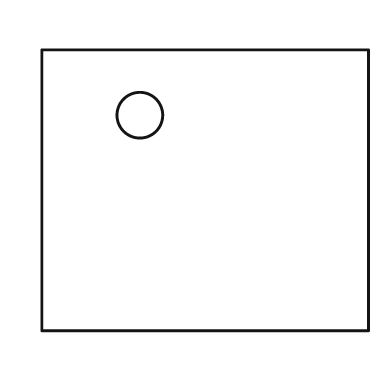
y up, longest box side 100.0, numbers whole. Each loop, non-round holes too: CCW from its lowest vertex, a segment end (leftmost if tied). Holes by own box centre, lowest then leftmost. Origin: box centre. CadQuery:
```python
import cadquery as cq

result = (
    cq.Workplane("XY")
    .moveTo(-50.0, -43.0)
    .lineTo(50.0, -43.0)
    .lineTo(50.0, 43.0)
    .lineTo(-50.0, 43.0)
    .close()
    .moveTo(-20.0, 23.0)
    .circle(7.0)
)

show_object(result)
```